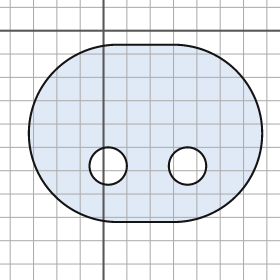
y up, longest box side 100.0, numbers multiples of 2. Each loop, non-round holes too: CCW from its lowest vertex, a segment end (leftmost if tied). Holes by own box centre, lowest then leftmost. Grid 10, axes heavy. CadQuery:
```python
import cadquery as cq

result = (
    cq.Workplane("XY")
    .moveTo(6.0, -82.0)
    .lineTo(30.0, -82.0)
    .threePointArc((68.0, -44.0), (30.0, -6.0))
    .lineTo(6.0, -6.0)
    .threePointArc((-32.0, -44.0), (6.0, -82.0))
    .close()
    .moveTo(2.0, -58.0)
    .circle(8.0)
    .moveTo(36.0, -58.0)
    .circle(8.0)
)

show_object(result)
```